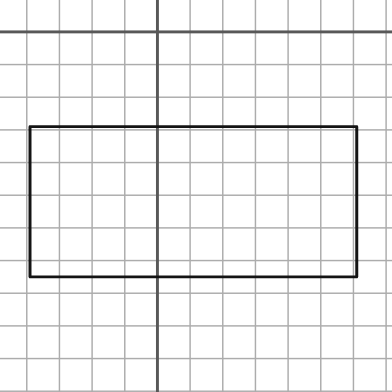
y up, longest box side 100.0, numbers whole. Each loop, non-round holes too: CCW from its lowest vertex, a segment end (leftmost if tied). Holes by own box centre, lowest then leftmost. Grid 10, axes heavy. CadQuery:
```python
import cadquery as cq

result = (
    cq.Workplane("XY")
    .moveTo(-39.0, -75.0)
    .lineTo(61.0, -75.0)
    .lineTo(61.0, -29.0)
    .lineTo(-39.0, -29.0)
    .close()
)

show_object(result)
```